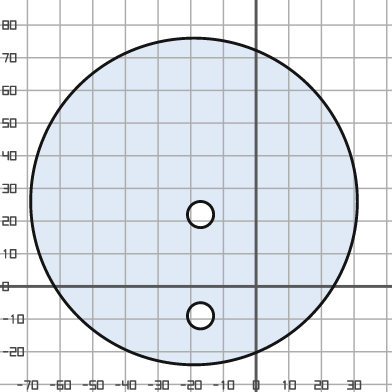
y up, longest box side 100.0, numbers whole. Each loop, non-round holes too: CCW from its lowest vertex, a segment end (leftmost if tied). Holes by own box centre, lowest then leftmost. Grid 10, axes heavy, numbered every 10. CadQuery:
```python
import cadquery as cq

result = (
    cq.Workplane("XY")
    .moveTo(-19.0, 26.0)
    .circle(50.0)
    .moveTo(-17.0, -9.0)
    .circle(4.0)
    .moveTo(-17.0, 22.0)
    .circle(4.0)
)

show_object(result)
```